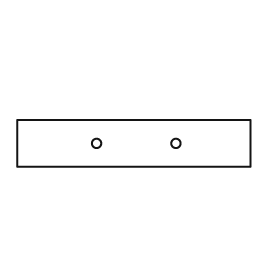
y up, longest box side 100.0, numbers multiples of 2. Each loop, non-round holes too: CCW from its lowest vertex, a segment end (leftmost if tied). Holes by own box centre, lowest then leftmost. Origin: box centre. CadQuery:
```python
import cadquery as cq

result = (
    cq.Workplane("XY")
    .moveTo(-50.0, -10.0)
    .lineTo(50.0, -10.0)
    .lineTo(50.0, 10.0)
    .lineTo(-50.0, 10.0)
    .close()
    .moveTo(-16.0, 0.0)
    .circle(2.0)
    .moveTo(18.0, 0.0)
    .circle(2.0)
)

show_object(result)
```